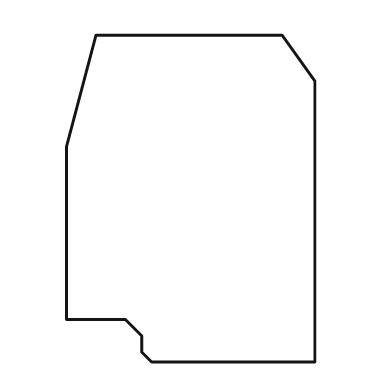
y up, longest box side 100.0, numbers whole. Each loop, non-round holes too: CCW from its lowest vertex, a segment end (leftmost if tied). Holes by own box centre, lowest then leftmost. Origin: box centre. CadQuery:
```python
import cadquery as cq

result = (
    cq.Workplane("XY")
    .moveTo(-12.0, -50.0)
    .lineTo(38.0, -50.0)
    .lineTo(38.0, 36.0)
    .lineTo(28.0, 50.0)
    .lineTo(-29.0, 50.0)
    .lineTo(-38.0, 16.0)
    .lineTo(-38.0, -37.0)
    .lineTo(-20.0, -37.0)
    .lineTo(-15.0, -42.0)
    .lineTo(-15.0, -47.0)
    .close()
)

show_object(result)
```